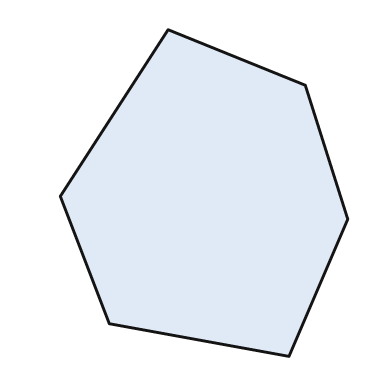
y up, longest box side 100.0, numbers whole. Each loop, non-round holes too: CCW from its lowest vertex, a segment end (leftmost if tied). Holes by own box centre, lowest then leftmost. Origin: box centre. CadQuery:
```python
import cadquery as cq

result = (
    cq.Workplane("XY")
    .moveTo(26.0, -50.0)
    .lineTo(44.0, -8.0)
    .lineTo(31.0, 33.0)
    .lineTo(-11.0, 50.0)
    .lineTo(-44.0, -1.0)
    .lineTo(-29.0, -40.0)
    .close()
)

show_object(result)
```